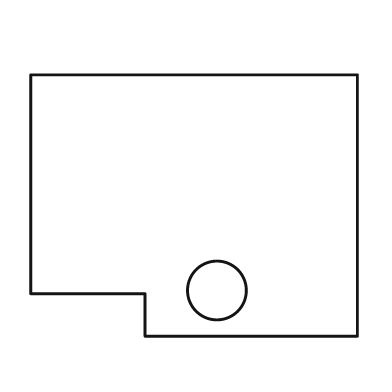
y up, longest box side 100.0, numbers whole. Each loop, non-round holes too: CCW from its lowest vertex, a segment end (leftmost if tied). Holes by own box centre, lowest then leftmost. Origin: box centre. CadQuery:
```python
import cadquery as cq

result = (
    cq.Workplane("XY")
    .moveTo(-15.0, -40.0)
    .lineTo(50.0, -40.0)
    .lineTo(50.0, 40.0)
    .lineTo(-50.0, 40.0)
    .lineTo(-50.0, -27.0)
    .lineTo(-15.0, -27.0)
    .close()
    .moveTo(7.0, -26.0)
    .circle(9.0)
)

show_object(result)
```